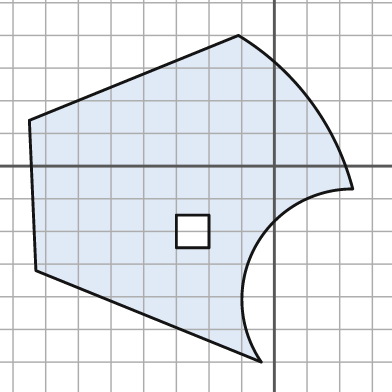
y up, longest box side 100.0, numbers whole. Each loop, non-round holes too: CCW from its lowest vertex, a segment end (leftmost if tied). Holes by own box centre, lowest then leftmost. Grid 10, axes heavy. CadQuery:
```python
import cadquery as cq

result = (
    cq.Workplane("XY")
    .moveTo(-4.0, -60.0)
    .threePointArc((-6.0, -25.0), (24.0, -7.0))
    .threePointArc((11.0, 20.0), (-11.0, 40.0))
    .lineTo(-75.0, 14.0)
    .lineTo(-73.0, -32.0)
    .close()
    .moveTo(-30.0, -25.0)
    .lineTo(-20.0, -25.0)
    .lineTo(-20.0, -15.0)
    .lineTo(-30.0, -15.0)
    .close()
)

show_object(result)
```